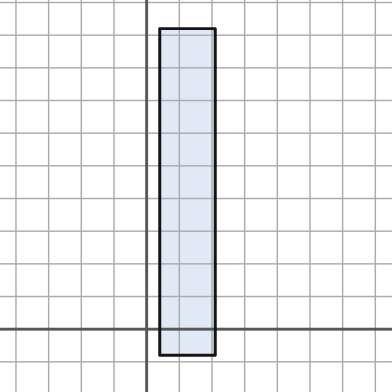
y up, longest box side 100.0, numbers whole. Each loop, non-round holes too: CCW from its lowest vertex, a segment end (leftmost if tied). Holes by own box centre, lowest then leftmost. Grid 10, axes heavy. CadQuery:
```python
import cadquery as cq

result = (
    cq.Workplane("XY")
    .moveTo(4.0, -8.0)
    .lineTo(21.0, -8.0)
    .lineTo(21.0, 92.0)
    .lineTo(4.0, 92.0)
    .close()
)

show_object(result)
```